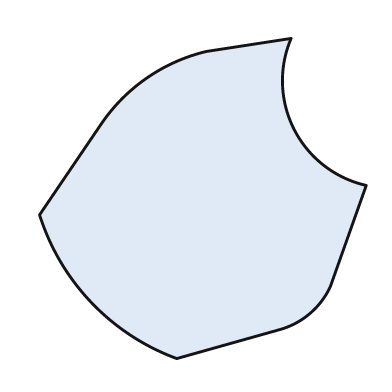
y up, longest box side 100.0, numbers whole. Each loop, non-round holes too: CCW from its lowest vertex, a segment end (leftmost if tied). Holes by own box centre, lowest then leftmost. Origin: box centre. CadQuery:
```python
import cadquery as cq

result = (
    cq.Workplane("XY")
    .moveTo(-8.0, -49.0)
    .lineTo(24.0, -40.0)
    .threePointArc((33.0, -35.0), (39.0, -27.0))
    .lineTo(50.0, 4.0)
    .threePointArc((28.0, 21.0), (27.0, 49.0))
    .lineTo(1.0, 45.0)
    .threePointArc((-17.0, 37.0), (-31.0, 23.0))
    .lineTo(-50.0, -5.0)
    .threePointArc((-34.0, -32.0), (-8.0, -49.0))
    .close()
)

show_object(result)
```